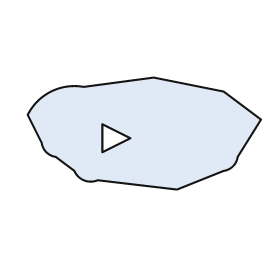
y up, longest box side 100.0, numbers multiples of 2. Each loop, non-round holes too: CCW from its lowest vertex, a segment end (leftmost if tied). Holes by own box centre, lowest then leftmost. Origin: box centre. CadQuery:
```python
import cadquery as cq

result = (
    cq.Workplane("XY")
    .moveTo(14.0, -24.0)
    .lineTo(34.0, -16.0)
    .threePointArc((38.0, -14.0), (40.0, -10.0))
    .lineTo(50.0, 6.0)
    .lineTo(34.0, 18.0)
    .lineTo(4.0, 24.0)
    .lineTo(-26.0, 20.0)
    .threePointArc((-40.0, 18.0), (-50.0, 8.0))
    .lineTo(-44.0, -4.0)
    .threePointArc((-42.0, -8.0), (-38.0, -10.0))
    .lineTo(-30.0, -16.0)
    .threePointArc((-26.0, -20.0), (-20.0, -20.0))
    .close()
    .moveTo(-18.0, -8.0)
    .lineTo(-6.0, -2.0)
    .lineTo(-18.0, 4.0)
    .close()
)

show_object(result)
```